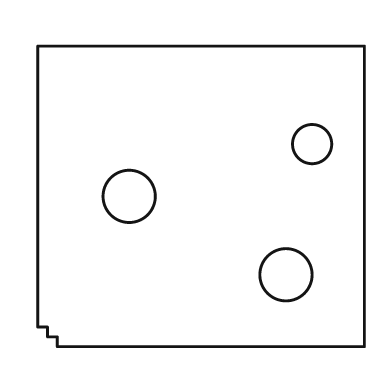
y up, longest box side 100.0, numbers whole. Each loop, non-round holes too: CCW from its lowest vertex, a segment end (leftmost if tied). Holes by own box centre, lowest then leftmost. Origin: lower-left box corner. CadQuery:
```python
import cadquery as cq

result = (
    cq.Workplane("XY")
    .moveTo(6.0, 0.0)
    .lineTo(100.0, 0.0)
    .lineTo(100.0, 92.0)
    .lineTo(0.0, 92.0)
    .lineTo(0.0, 6.0)
    .lineTo(3.0, 6.0)
    .lineTo(3.0, 3.0)
    .lineTo(6.0, 3.0)
    .close()
    .moveTo(76.0, 22.0)
    .circle(8.0)
    .moveTo(28.0, 46.0)
    .circle(8.0)
    .moveTo(84.0, 62.0)
    .circle(6.0)
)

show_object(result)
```